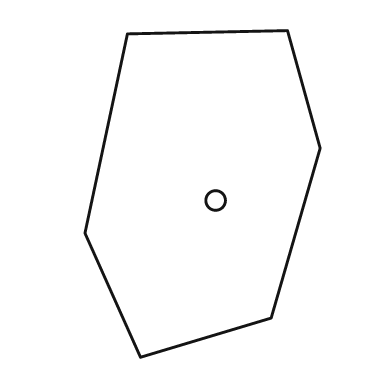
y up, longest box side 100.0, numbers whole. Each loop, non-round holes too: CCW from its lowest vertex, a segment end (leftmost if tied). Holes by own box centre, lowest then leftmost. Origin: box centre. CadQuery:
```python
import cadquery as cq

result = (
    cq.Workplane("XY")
    .moveTo(-19.0, -50.0)
    .lineTo(21.0, -38.0)
    .lineTo(36.0, 14.0)
    .lineTo(26.0, 50.0)
    .lineTo(-23.0, 49.0)
    .lineTo(-36.0, -12.0)
    .close()
    .moveTo(4.0, -2.0)
    .circle(3.0)
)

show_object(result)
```